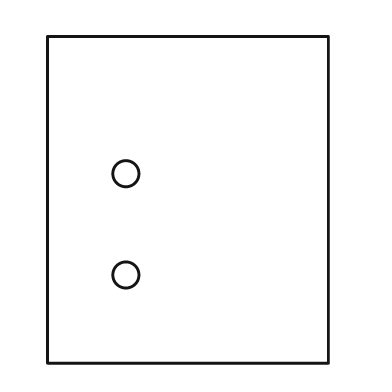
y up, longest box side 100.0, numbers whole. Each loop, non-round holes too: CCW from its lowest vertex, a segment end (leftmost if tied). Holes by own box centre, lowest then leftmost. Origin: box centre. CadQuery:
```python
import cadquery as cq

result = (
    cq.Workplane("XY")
    .moveTo(-43.0, -50.0)
    .lineTo(43.0, -50.0)
    .lineTo(43.0, 50.0)
    .lineTo(-43.0, 50.0)
    .close()
    .moveTo(-19.0, -23.0)
    .circle(4.0)
    .moveTo(-19.0, 8.0)
    .circle(4.0)
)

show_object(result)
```